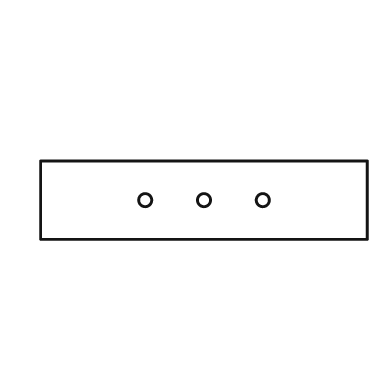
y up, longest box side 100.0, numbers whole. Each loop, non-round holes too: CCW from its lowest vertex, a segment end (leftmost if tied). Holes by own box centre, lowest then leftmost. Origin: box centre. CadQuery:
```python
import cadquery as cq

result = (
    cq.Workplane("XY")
    .moveTo(-50.0, -12.0)
    .lineTo(50.0, -12.0)
    .lineTo(50.0, 12.0)
    .lineTo(-50.0, 12.0)
    .close()
    .moveTo(-18.0, 0.0)
    .circle(2.0)
    .moveTo(0.0, 0.0)
    .circle(2.0)
    .moveTo(18.0, 0.0)
    .circle(2.0)
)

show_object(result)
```